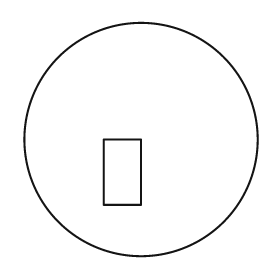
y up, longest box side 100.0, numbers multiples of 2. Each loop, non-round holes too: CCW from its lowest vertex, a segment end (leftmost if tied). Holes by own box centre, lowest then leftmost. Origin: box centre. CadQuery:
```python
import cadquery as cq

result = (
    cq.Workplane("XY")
    .moveTo(0.0, 0.0)
    .circle(50.0)
    .moveTo(-16.0, -28.0)
    .lineTo(0.0, -28.0)
    .lineTo(0.0, 0.0)
    .lineTo(-16.0, 0.0)
    .close()
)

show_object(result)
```